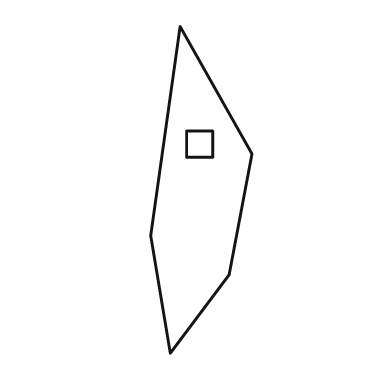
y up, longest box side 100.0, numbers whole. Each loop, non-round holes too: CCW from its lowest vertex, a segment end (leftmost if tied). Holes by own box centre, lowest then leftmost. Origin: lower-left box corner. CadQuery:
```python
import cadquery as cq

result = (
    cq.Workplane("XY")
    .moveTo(6.0, 0.0)
    .lineTo(24.0, 24.0)
    .lineTo(31.0, 61.0)
    .lineTo(9.0, 100.0)
    .lineTo(0.0, 36.0)
    .close()
    .moveTo(11.0, 60.0)
    .lineTo(19.0, 60.0)
    .lineTo(19.0, 68.0)
    .lineTo(11.0, 68.0)
    .close()
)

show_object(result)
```